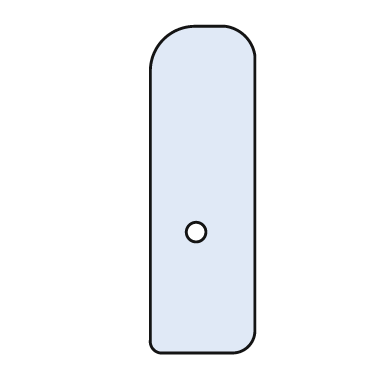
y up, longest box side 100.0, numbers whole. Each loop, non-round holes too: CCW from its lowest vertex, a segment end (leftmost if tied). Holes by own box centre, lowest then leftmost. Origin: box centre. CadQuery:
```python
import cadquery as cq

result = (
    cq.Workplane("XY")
    .moveTo(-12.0, -50.0)
    .lineTo(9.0, -50.0)
    .threePointArc((14.0, -48.0), (16.0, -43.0))
    .lineTo(16.0, 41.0)
    .threePointArc((13.0, 47.0), (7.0, 50.0))
    .lineTo(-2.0, 50.0)
    .threePointArc((-12.0, 46.0), (-16.0, 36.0))
    .lineTo(-16.0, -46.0)
    .threePointArc((-15.0, -49.0), (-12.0, -50.0))
    .close()
    .moveTo(-2.0, -13.0)
    .circle(3.0)
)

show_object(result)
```